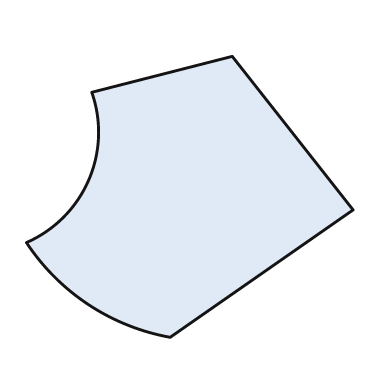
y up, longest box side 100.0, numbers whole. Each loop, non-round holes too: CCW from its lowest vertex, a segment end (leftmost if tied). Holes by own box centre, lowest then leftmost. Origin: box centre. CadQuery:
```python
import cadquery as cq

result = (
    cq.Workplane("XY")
    .moveTo(-6.0, -43.0)
    .lineTo(50.0, -4.0)
    .lineTo(13.0, 43.0)
    .lineTo(-30.0, 32.0)
    .threePointArc((-31.0, 5.0), (-50.0, -14.0))
    .threePointArc((-31.0, -33.0), (-6.0, -43.0))
    .close()
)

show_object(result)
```